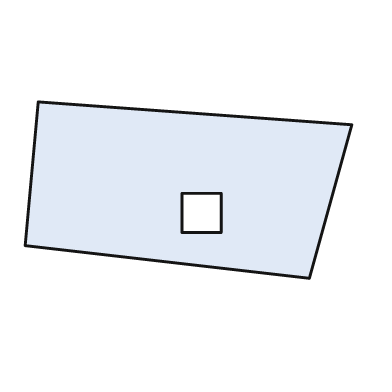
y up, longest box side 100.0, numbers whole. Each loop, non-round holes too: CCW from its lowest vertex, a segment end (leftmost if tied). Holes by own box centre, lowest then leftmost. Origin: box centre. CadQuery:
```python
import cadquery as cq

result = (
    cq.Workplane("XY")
    .moveTo(37.0, -27.0)
    .lineTo(50.0, 20.0)
    .lineTo(-46.0, 27.0)
    .lineTo(-50.0, -17.0)
    .close()
    .moveTo(-2.0, -13.0)
    .lineTo(10.0, -13.0)
    .lineTo(10.0, -1.0)
    .lineTo(-2.0, -1.0)
    .close()
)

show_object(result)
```